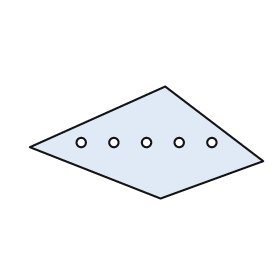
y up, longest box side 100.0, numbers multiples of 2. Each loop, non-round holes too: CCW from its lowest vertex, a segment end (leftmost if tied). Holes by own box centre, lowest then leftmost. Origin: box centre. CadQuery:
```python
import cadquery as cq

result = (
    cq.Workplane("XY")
    .moveTo(6.0, -24.0)
    .lineTo(50.0, -8.0)
    .lineTo(8.0, 24.0)
    .lineTo(-50.0, -2.0)
    .close()
    .moveTo(-28.0, 0.0)
    .circle(2.0)
    .moveTo(-14.0, 0.0)
    .circle(2.0)
    .moveTo(0.0, 0.0)
    .circle(2.0)
    .moveTo(14.0, 0.0)
    .circle(2.0)
    .moveTo(28.0, 0.0)
    .circle(2.0)
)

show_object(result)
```